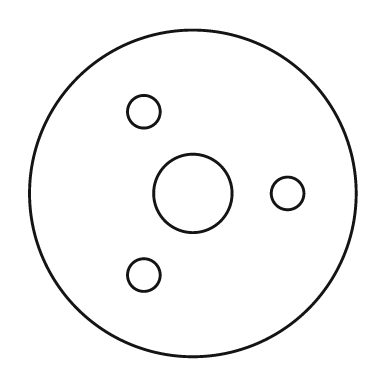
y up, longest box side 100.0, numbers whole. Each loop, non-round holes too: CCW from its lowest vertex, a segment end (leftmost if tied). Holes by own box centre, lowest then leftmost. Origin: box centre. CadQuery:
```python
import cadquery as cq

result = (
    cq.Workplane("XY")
    .moveTo(0.0, 0.0)
    .circle(50.0)
    .moveTo(-15.0, -25.0)
    .circle(5.0)
    .moveTo(0.0, 0.0)
    .circle(12.0)
    .moveTo(29.0, 0.0)
    .circle(5.0)
    .moveTo(-15.0, 25.0)
    .circle(5.0)
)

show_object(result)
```